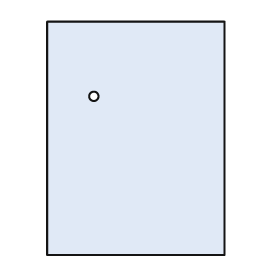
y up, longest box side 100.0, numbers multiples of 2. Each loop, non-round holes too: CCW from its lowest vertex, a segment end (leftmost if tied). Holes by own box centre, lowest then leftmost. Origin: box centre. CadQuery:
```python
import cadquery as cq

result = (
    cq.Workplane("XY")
    .moveTo(-38.0, -50.0)
    .lineTo(38.0, -50.0)
    .lineTo(38.0, 50.0)
    .lineTo(-38.0, 50.0)
    .close()
    .moveTo(-18.0, 18.0)
    .circle(2.0)
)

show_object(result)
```